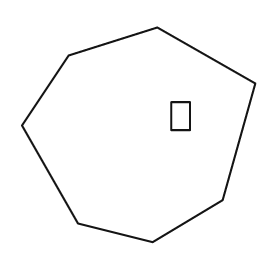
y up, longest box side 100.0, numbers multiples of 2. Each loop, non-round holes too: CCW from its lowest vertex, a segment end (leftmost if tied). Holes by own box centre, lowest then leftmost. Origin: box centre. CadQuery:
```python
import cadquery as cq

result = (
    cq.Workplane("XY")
    .moveTo(6.0, -46.0)
    .lineTo(36.0, -28.0)
    .lineTo(50.0, 22.0)
    .lineTo(8.0, 46.0)
    .lineTo(-30.0, 34.0)
    .lineTo(-50.0, 4.0)
    .lineTo(-26.0, -38.0)
    .close()
    .moveTo(14.0, 2.0)
    .lineTo(22.0, 2.0)
    .lineTo(22.0, 14.0)
    .lineTo(14.0, 14.0)
    .close()
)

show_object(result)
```